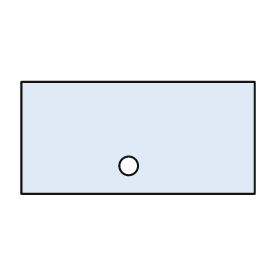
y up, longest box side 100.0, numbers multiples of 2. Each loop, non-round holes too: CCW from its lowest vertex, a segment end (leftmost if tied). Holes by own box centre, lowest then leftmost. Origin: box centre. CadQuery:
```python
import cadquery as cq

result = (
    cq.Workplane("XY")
    .moveTo(-50.0, -24.0)
    .lineTo(50.0, -24.0)
    .lineTo(50.0, 24.0)
    .lineTo(-50.0, 24.0)
    .close()
    .moveTo(-4.0, -12.0)
    .circle(4.0)
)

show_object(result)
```